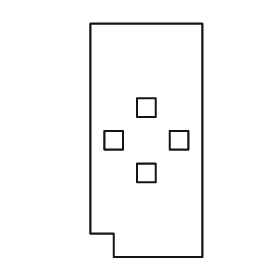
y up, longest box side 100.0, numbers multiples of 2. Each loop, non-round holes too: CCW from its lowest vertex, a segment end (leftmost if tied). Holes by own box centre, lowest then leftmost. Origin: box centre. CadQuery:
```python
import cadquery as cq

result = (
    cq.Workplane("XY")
    .moveTo(-14.0, -50.0)
    .lineTo(24.0, -50.0)
    .lineTo(24.0, 50.0)
    .lineTo(-24.0, 50.0)
    .lineTo(-24.0, -40.0)
    .lineTo(-14.0, -40.0)
    .close()
    .moveTo(-4.0, -18.0)
    .lineTo(4.0, -18.0)
    .lineTo(4.0, -10.0)
    .lineTo(-4.0, -10.0)
    .close()
    .moveTo(-18.0, -4.0)
    .lineTo(-10.0, -4.0)
    .lineTo(-10.0, 4.0)
    .lineTo(-18.0, 4.0)
    .close()
    .moveTo(10.0, -4.0)
    .lineTo(18.0, -4.0)
    .lineTo(18.0, 4.0)
    .lineTo(10.0, 4.0)
    .close()
    .moveTo(-4.0, 10.0)
    .lineTo(4.0, 10.0)
    .lineTo(4.0, 18.0)
    .lineTo(-4.0, 18.0)
    .close()
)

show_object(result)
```